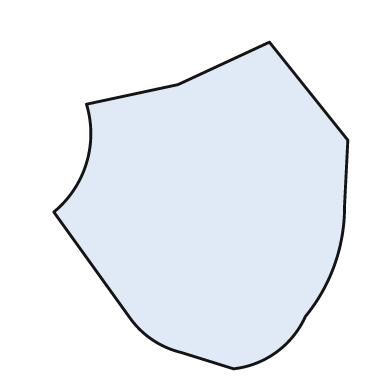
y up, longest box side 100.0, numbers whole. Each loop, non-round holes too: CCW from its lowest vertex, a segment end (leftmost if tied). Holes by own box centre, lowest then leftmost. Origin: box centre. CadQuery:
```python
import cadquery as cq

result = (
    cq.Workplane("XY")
    .moveTo(10.0, -50.0)
    .threePointArc((23.0, -45.0), (32.0, -34.0))
    .threePointArc((41.0, -18.0), (44.0, 0.0))
    .lineTo(45.0, 20.0)
    .lineTo(21.0, 50.0)
    .lineTo(-7.0, 37.0)
    .lineTo(-35.0, 31.0)
    .threePointArc((-35.0, 13.0), (-45.0, -2.0))
    .lineTo(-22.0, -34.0)
    .threePointArc((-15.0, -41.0), (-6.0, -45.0))
    .close()
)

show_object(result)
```